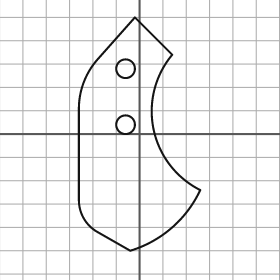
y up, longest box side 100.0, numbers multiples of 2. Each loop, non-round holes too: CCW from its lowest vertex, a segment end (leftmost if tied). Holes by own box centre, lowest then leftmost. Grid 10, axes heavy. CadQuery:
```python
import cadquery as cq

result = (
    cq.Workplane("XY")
    .moveTo(-4.0, -50.0)
    .threePointArc((14.0, -40.0), (26.0, -24.0))
    .threePointArc((6.0, 2.0), (14.0, 34.0))
    .lineTo(-2.0, 50.0)
    .lineTo(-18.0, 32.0)
    .threePointArc((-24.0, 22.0), (-26.0, 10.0))
    .lineTo(-26.0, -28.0)
    .threePointArc((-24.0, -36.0), (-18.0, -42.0))
    .close()
    .moveTo(-6.0, 4.0)
    .circle(4.0)
    .moveTo(-6.0, 28.0)
    .circle(4.0)
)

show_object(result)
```